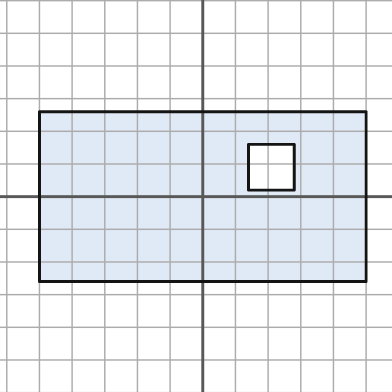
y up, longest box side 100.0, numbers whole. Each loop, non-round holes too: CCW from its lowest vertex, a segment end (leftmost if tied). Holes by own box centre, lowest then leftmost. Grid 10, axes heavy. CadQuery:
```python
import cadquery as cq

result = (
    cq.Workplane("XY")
    .moveTo(-50.0, -26.0)
    .lineTo(50.0, -26.0)
    .lineTo(50.0, 26.0)
    .lineTo(-50.0, 26.0)
    .close()
    .moveTo(14.0, 2.0)
    .lineTo(28.0, 2.0)
    .lineTo(28.0, 16.0)
    .lineTo(14.0, 16.0)
    .close()
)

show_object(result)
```